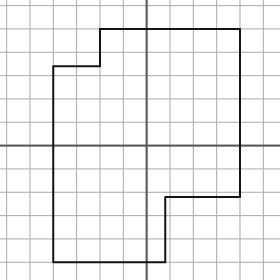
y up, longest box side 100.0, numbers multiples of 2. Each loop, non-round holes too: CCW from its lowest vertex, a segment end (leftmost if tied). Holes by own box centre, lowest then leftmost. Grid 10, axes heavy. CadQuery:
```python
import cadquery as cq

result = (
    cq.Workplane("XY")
    .moveTo(-40.0, -50.0)
    .lineTo(8.0, -50.0)
    .lineTo(8.0, -22.0)
    .lineTo(40.0, -22.0)
    .lineTo(40.0, 50.0)
    .lineTo(-20.0, 50.0)
    .lineTo(-20.0, 34.0)
    .lineTo(-40.0, 34.0)
    .close()
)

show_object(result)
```